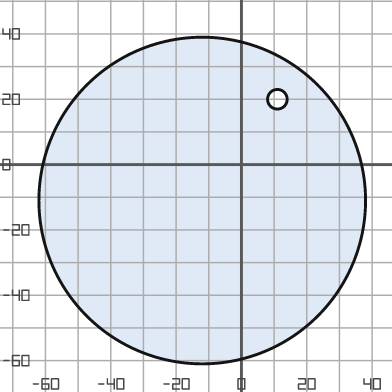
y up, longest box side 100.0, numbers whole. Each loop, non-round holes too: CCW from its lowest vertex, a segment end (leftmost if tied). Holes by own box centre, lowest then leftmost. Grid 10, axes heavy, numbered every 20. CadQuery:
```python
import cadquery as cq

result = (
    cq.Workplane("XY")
    .moveTo(-12.0, -11.0)
    .circle(50.0)
    .moveTo(11.0, 20.0)
    .circle(3.0)
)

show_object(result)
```